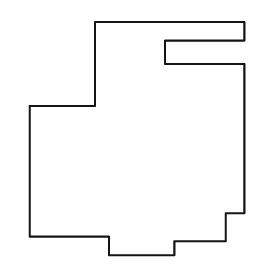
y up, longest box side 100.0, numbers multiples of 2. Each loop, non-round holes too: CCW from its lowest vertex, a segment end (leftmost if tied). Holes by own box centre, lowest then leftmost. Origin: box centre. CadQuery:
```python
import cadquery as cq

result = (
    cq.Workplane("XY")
    .moveTo(-12.0, -50.0)
    .lineTo(16.0, -50.0)
    .lineTo(16.0, -44.0)
    .lineTo(38.0, -44.0)
    .lineTo(38.0, -32.0)
    .lineTo(46.0, -32.0)
    .lineTo(46.0, 32.0)
    .lineTo(12.0, 32.0)
    .lineTo(12.0, 42.0)
    .lineTo(46.0, 42.0)
    .lineTo(46.0, 50.0)
    .lineTo(-18.0, 50.0)
    .lineTo(-18.0, 14.0)
    .lineTo(-46.0, 14.0)
    .lineTo(-46.0, -42.0)
    .lineTo(-12.0, -42.0)
    .close()
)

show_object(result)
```